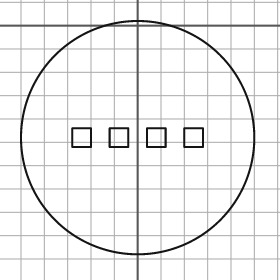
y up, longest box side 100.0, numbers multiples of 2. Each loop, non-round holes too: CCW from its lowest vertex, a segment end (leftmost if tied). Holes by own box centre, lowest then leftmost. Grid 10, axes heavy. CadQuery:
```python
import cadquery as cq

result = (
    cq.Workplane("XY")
    .moveTo(0.0, -48.0)
    .circle(50.0)
    .moveTo(-28.0, -52.0)
    .lineTo(-20.0, -52.0)
    .lineTo(-20.0, -44.0)
    .lineTo(-28.0, -44.0)
    .close()
    .moveTo(-12.0, -52.0)
    .lineTo(-4.0, -52.0)
    .lineTo(-4.0, -44.0)
    .lineTo(-12.0, -44.0)
    .close()
    .moveTo(4.0, -52.0)
    .lineTo(12.0, -52.0)
    .lineTo(12.0, -44.0)
    .lineTo(4.0, -44.0)
    .close()
    .moveTo(20.0, -52.0)
    .lineTo(28.0, -52.0)
    .lineTo(28.0, -44.0)
    .lineTo(20.0, -44.0)
    .close()
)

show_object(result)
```